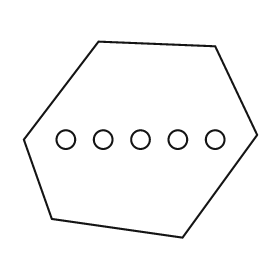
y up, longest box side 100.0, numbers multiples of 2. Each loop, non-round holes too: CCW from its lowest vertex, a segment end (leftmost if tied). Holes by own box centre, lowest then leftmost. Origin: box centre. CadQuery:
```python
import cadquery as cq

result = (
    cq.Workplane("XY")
    .moveTo(18.0, -42.0)
    .lineTo(50.0, 2.0)
    .lineTo(32.0, 40.0)
    .lineTo(-18.0, 42.0)
    .lineTo(-50.0, 0.0)
    .lineTo(-38.0, -34.0)
    .close()
    .moveTo(-32.0, 0.0)
    .circle(4.0)
    .moveTo(-16.0, 0.0)
    .circle(4.0)
    .moveTo(0.0, 0.0)
    .circle(4.0)
    .moveTo(16.0, 0.0)
    .circle(4.0)
    .moveTo(32.0, 0.0)
    .circle(4.0)
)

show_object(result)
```